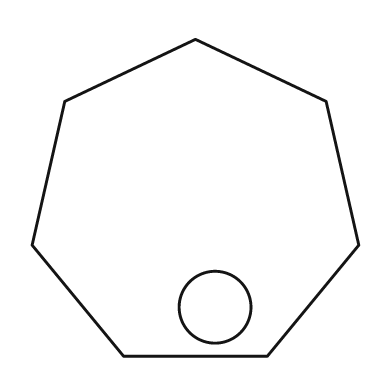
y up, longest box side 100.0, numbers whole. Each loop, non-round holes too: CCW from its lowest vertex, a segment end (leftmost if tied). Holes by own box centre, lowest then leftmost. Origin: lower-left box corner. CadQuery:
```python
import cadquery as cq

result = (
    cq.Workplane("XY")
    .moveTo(28.0, 0.0)
    .lineTo(72.0, 0.0)
    .lineTo(100.0, 34.0)
    .lineTo(90.0, 78.0)
    .lineTo(50.0, 97.0)
    .lineTo(10.0, 78.0)
    .lineTo(0.0, 34.0)
    .close()
    .moveTo(56.0, 15.0)
    .circle(11.0)
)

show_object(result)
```